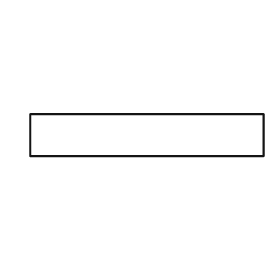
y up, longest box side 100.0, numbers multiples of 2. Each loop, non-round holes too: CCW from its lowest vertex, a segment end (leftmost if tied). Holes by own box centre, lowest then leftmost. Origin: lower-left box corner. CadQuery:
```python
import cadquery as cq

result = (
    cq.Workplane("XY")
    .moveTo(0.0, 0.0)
    .lineTo(100.0, 0.0)
    .lineTo(100.0, 18.0)
    .lineTo(0.0, 18.0)
    .close()
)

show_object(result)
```